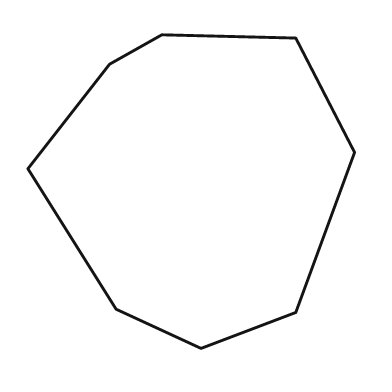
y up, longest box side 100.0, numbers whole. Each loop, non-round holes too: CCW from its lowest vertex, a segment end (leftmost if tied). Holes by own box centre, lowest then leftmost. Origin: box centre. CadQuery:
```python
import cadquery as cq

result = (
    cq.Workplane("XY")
    .moveTo(3.0, -48.0)
    .lineTo(32.0, -37.0)
    .lineTo(50.0, 12.0)
    .lineTo(32.0, 47.0)
    .lineTo(-9.0, 48.0)
    .lineTo(-25.0, 39.0)
    .lineTo(-50.0, 7.0)
    .lineTo(-23.0, -36.0)
    .close()
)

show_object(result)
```